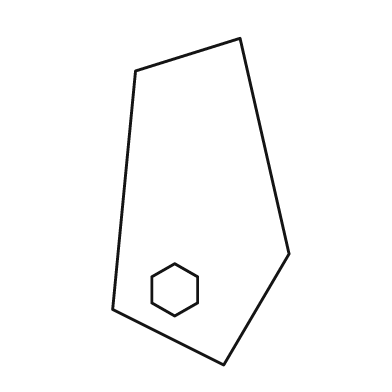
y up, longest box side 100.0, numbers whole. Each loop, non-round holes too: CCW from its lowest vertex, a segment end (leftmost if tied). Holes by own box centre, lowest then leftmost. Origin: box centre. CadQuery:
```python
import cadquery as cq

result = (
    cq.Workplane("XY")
    .moveTo(7.0, -50.0)
    .lineTo(27.0, -16.0)
    .lineTo(12.0, 50.0)
    .lineTo(-20.0, 40.0)
    .lineTo(-27.0, -33.0)
    .close()
    .moveTo(-8.0, -35.0)
    .lineTo(-1.0, -31.0)
    .lineTo(-1.0, -23.0)
    .lineTo(-8.0, -19.0)
    .lineTo(-15.0, -23.0)
    .lineTo(-15.0, -31.0)
    .close()
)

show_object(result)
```